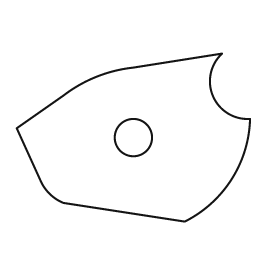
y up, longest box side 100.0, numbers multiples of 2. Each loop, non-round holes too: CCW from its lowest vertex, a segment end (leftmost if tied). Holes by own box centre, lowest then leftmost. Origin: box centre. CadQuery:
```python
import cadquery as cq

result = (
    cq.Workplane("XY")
    .moveTo(22.0, -36.0)
    .threePointArc((42.0, -18.0), (50.0, 8.0))
    .threePointArc((34.0, 18.0), (38.0, 36.0))
    .lineTo(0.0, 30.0)
    .threePointArc((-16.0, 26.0), (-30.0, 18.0))
    .lineTo(-50.0, 4.0)
    .lineTo(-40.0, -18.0)
    .threePointArc((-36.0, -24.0), (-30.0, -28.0))
    .close()
    .moveTo(0.0, 0.0)
    .circle(8.0)
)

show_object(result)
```